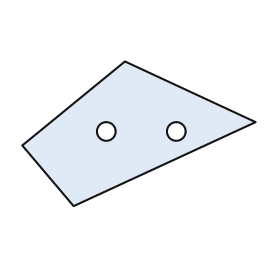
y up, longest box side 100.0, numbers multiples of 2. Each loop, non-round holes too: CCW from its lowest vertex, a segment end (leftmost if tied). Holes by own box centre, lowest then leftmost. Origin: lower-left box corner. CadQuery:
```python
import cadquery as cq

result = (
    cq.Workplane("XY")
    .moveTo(22.0, 0.0)
    .lineTo(100.0, 36.0)
    .lineTo(44.0, 62.0)
    .lineTo(0.0, 26.0)
    .close()
    .moveTo(36.0, 32.0)
    .circle(4.0)
    .moveTo(66.0, 32.0)
    .circle(4.0)
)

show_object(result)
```